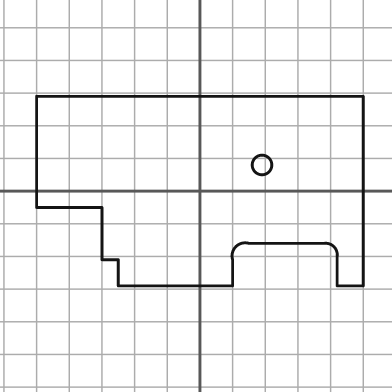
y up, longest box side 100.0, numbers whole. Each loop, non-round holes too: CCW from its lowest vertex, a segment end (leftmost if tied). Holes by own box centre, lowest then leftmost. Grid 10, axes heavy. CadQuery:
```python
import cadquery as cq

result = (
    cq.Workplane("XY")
    .moveTo(-25.0, -29.0)
    .lineTo(10.0, -29.0)
    .lineTo(10.0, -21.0)
    .threePointArc((11.0, -17.0), (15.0, -16.0))
    .lineTo(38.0, -16.0)
    .threePointArc((41.0, -17.0), (42.0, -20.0))
    .lineTo(42.0, -29.0)
    .lineTo(50.0, -29.0)
    .lineTo(50.0, 29.0)
    .lineTo(-50.0, 29.0)
    .lineTo(-50.0, -5.0)
    .lineTo(-30.0, -5.0)
    .lineTo(-30.0, -21.0)
    .lineTo(-25.0, -21.0)
    .close()
    .moveTo(19.0, 8.0)
    .circle(3.0)
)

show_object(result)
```